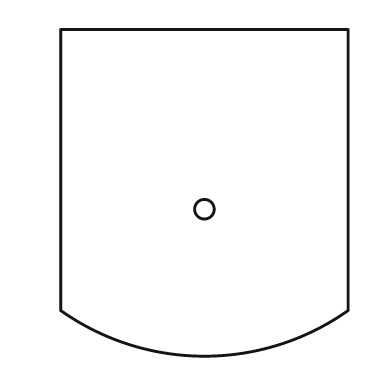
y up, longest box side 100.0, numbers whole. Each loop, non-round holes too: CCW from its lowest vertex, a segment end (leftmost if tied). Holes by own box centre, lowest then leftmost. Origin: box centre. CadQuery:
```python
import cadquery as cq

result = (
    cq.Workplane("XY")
    .moveTo(-44.0, -36.0)
    .threePointArc((0.0, -50.0), (44.0, -36.0))
    .lineTo(44.0, 50.0)
    .lineTo(-44.0, 50.0)
    .close()
    .moveTo(0.0, -5.0)
    .circle(3.0)
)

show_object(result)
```